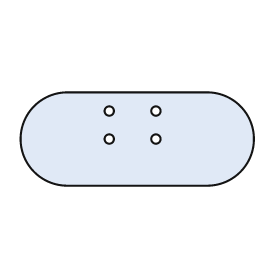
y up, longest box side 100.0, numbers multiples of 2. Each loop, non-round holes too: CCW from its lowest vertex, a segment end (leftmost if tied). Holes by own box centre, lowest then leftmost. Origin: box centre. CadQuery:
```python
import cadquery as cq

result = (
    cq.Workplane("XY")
    .moveTo(-30.0, -20.0)
    .lineTo(30.0, -20.0)
    .threePointArc((50.0, 0.0), (30.0, 20.0))
    .lineTo(-30.0, 20.0)
    .threePointArc((-50.0, 0.0), (-30.0, -20.0))
    .close()
    .moveTo(-12.0, 0.0)
    .circle(2.0)
    .moveTo(8.0, 0.0)
    .circle(2.0)
    .moveTo(-12.0, 12.0)
    .circle(2.0)
    .moveTo(8.0, 12.0)
    .circle(2.0)
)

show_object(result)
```